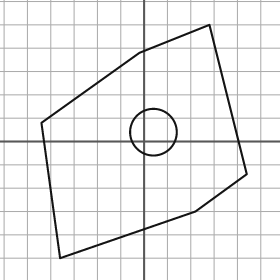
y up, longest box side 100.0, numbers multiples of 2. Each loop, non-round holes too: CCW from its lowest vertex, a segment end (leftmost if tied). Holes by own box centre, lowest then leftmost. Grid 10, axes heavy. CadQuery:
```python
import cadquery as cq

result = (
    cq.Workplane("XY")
    .moveTo(-36.0, -50.0)
    .lineTo(22.0, -30.0)
    .lineTo(44.0, -14.0)
    .lineTo(28.0, 50.0)
    .lineTo(-2.0, 38.0)
    .lineTo(-44.0, 8.0)
    .close()
    .moveTo(4.0, 4.0)
    .circle(10.0)
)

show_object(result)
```